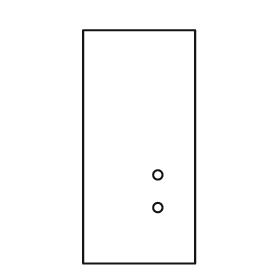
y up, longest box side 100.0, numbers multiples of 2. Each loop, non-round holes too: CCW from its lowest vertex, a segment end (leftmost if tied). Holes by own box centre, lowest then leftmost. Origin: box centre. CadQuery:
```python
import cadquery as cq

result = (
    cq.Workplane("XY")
    .moveTo(-24.0, -50.0)
    .lineTo(24.0, -50.0)
    .lineTo(24.0, 50.0)
    .lineTo(-24.0, 50.0)
    .close()
    .moveTo(8.0, -26.0)
    .circle(2.0)
    .moveTo(8.0, -12.0)
    .circle(2.0)
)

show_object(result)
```